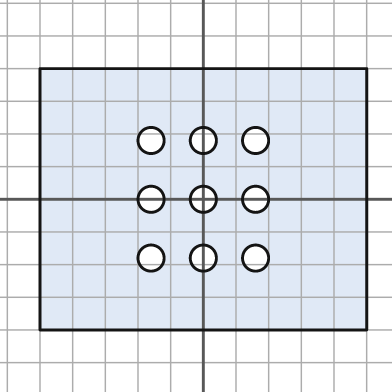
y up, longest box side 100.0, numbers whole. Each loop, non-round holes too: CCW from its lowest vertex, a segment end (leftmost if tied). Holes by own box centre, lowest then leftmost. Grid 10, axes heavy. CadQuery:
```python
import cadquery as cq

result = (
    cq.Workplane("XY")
    .moveTo(-50.0, -40.0)
    .lineTo(50.0, -40.0)
    .lineTo(50.0, 40.0)
    .lineTo(-50.0, 40.0)
    .close()
    .moveTo(-16.0, -18.0)
    .circle(4.0)
    .moveTo(0.0, -18.0)
    .circle(4.0)
    .moveTo(16.0, -18.0)
    .circle(4.0)
    .moveTo(-16.0, 0.0)
    .circle(4.0)
    .moveTo(0.0, 0.0)
    .circle(4.0)
    .moveTo(16.0, 0.0)
    .circle(4.0)
    .moveTo(-16.0, 18.0)
    .circle(4.0)
    .moveTo(0.0, 18.0)
    .circle(4.0)
    .moveTo(16.0, 18.0)
    .circle(4.0)
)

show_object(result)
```